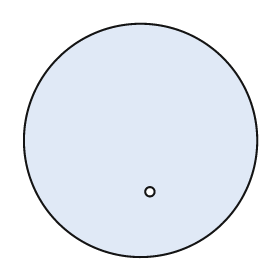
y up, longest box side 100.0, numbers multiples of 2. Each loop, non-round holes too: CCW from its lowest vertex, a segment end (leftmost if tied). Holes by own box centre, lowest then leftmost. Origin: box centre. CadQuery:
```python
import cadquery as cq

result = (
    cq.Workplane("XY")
    .moveTo(0.0, 0.0)
    .circle(50.0)
    .moveTo(4.0, -22.0)
    .circle(2.0)
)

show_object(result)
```